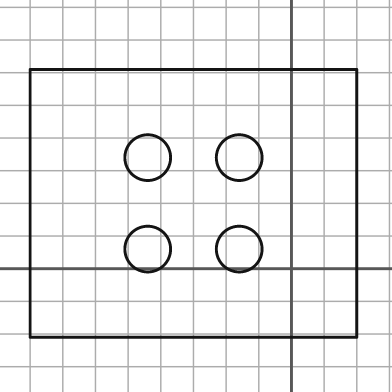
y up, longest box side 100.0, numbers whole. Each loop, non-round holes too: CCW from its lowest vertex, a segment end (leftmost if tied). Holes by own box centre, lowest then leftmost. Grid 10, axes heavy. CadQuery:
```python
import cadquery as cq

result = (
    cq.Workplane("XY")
    .moveTo(-80.0, -21.0)
    .lineTo(20.0, -21.0)
    .lineTo(20.0, 61.0)
    .lineTo(-80.0, 61.0)
    .close()
    .moveTo(-44.0, 6.0)
    .circle(7.0)
    .moveTo(-16.0, 6.0)
    .circle(7.0)
    .moveTo(-44.0, 34.0)
    .circle(7.0)
    .moveTo(-16.0, 34.0)
    .circle(7.0)
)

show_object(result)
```